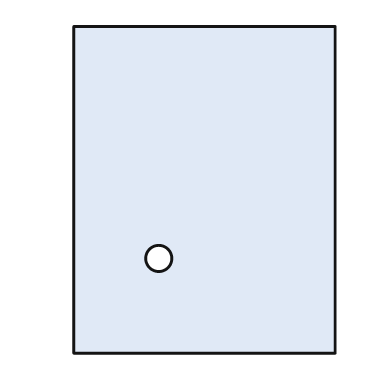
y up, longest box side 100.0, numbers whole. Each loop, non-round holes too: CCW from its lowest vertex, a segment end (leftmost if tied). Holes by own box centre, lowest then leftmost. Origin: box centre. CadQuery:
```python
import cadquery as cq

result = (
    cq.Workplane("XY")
    .moveTo(-40.0, -50.0)
    .lineTo(40.0, -50.0)
    .lineTo(40.0, 50.0)
    .lineTo(-40.0, 50.0)
    .close()
    .moveTo(-14.0, -21.0)
    .circle(4.0)
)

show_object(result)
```